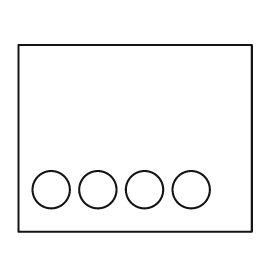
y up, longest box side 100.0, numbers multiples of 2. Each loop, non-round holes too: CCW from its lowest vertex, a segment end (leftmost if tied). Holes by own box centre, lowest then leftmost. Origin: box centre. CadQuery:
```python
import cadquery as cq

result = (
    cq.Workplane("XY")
    .moveTo(-50.0, -40.0)
    .lineTo(50.0, -40.0)
    .lineTo(50.0, 40.0)
    .lineTo(-50.0, 40.0)
    .close()
    .moveTo(-36.0, -22.0)
    .circle(8.0)
    .moveTo(-16.0, -22.0)
    .circle(8.0)
    .moveTo(4.0, -22.0)
    .circle(8.0)
    .moveTo(24.0, -22.0)
    .circle(8.0)
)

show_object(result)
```